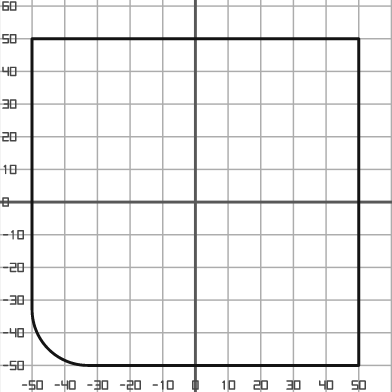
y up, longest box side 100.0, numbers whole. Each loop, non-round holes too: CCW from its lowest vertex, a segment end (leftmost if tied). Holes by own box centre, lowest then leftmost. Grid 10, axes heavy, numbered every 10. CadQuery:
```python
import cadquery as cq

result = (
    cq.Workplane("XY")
    .moveTo(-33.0, -50.0)
    .lineTo(50.0, -50.0)
    .lineTo(50.0, 50.0)
    .lineTo(-50.0, 50.0)
    .lineTo(-50.0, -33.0)
    .threePointArc((-45.0, -45.0), (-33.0, -50.0))
    .close()
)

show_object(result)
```